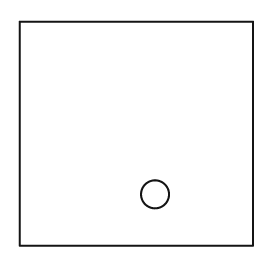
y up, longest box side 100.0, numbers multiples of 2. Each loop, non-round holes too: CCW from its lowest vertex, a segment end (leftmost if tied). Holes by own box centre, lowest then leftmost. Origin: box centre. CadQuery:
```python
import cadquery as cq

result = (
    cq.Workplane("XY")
    .moveTo(-50.0, -48.0)
    .lineTo(50.0, -48.0)
    .lineTo(50.0, 48.0)
    .lineTo(-50.0, 48.0)
    .close()
    .moveTo(8.0, -26.0)
    .circle(6.0)
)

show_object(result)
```